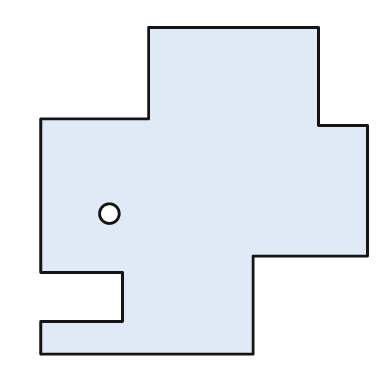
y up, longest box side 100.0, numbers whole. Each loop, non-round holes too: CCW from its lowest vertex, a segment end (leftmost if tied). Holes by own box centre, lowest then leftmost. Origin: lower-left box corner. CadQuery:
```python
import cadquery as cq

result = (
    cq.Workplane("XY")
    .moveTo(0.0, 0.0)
    .lineTo(65.0, 0.0)
    .lineTo(65.0, 30.0)
    .lineTo(100.0, 30.0)
    .lineTo(100.0, 70.0)
    .lineTo(85.0, 70.0)
    .lineTo(85.0, 100.0)
    .lineTo(33.0, 100.0)
    .lineTo(33.0, 72.0)
    .lineTo(0.0, 72.0)
    .lineTo(0.0, 25.0)
    .lineTo(25.0, 25.0)
    .lineTo(25.0, 10.0)
    .lineTo(0.0, 10.0)
    .close()
    .moveTo(21.0, 43.0)
    .circle(3.0)
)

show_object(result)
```